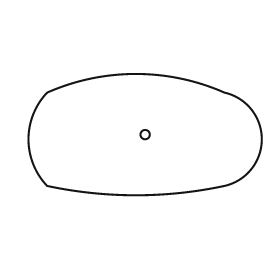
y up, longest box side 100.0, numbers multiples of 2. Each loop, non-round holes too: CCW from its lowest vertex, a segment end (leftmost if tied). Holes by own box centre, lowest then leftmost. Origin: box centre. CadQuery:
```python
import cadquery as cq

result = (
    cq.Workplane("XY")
    .moveTo(-42.0, -22.0)
    .threePointArc((-4.0, -26.0), (34.0, -22.0))
    .threePointArc((50.0, -2.0), (34.0, 18.0))
    .threePointArc((-4.0, 26.0), (-42.0, 18.0))
    .threePointArc((-50.0, -2.0), (-42.0, -22.0))
    .close()
    .moveTo(0.0, 0.0)
    .circle(2.0)
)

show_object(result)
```